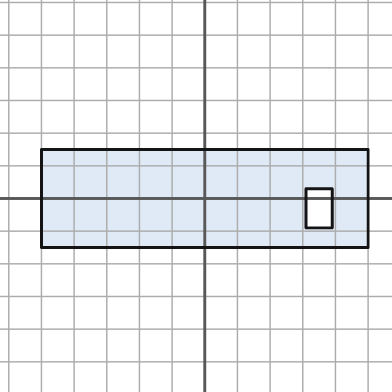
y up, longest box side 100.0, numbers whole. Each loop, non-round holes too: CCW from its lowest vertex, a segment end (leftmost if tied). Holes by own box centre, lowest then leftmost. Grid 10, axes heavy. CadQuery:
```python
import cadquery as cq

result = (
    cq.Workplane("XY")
    .moveTo(-50.0, -15.0)
    .lineTo(50.0, -15.0)
    .lineTo(50.0, 15.0)
    .lineTo(-50.0, 15.0)
    .close()
    .moveTo(31.0, -9.0)
    .lineTo(39.0, -9.0)
    .lineTo(39.0, 3.0)
    .lineTo(31.0, 3.0)
    .close()
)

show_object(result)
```